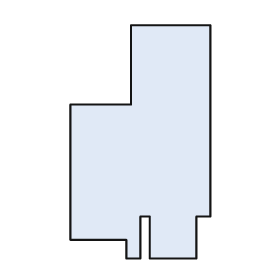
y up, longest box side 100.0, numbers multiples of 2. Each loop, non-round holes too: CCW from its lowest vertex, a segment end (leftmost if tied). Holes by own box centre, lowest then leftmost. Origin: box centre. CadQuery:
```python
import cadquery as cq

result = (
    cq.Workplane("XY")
    .moveTo(-6.0, -50.0)
    .lineTo(0.0, -50.0)
    .lineTo(0.0, -32.0)
    .lineTo(4.0, -32.0)
    .lineTo(4.0, -50.0)
    .lineTo(24.0, -50.0)
    .lineTo(24.0, -32.0)
    .lineTo(30.0, -32.0)
    .lineTo(30.0, 50.0)
    .lineTo(-4.0, 50.0)
    .lineTo(-4.0, 16.0)
    .lineTo(-30.0, 16.0)
    .lineTo(-30.0, -42.0)
    .lineTo(-6.0, -42.0)
    .close()
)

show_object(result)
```